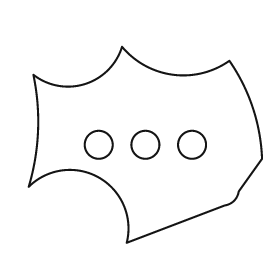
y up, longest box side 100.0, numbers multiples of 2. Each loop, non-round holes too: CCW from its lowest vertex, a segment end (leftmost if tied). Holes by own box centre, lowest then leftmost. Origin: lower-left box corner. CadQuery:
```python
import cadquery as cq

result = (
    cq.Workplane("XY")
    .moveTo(42.0, 0.0)
    .lineTo(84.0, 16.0)
    .threePointArc((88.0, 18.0), (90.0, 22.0))
    .lineTo(100.0, 36.0)
    .threePointArc((96.0, 58.0), (86.0, 78.0))
    .threePointArc((62.0, 72.0), (40.0, 84.0))
    .threePointArc((24.0, 68.0), (2.0, 72.0))
    .threePointArc((4.0, 48.0), (0.0, 24.0))
    .threePointArc((30.0, 28.0), (42.0, 0.0))
    .close()
    .moveTo(30.0, 42.0)
    .circle(6.0)
    .moveTo(50.0, 42.0)
    .circle(6.0)
    .moveTo(70.0, 42.0)
    .circle(6.0)
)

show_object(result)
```